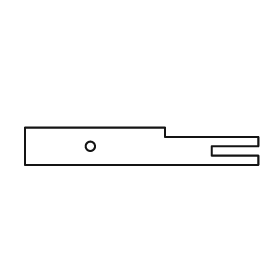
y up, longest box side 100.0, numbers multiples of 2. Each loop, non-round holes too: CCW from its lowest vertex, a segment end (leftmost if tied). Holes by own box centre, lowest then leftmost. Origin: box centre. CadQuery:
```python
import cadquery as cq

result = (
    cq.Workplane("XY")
    .moveTo(-50.0, -8.0)
    .lineTo(50.0, -8.0)
    .lineTo(50.0, -4.0)
    .lineTo(30.0, -4.0)
    .lineTo(30.0, 0.0)
    .lineTo(50.0, 0.0)
    .lineTo(50.0, 4.0)
    .lineTo(10.0, 4.0)
    .lineTo(10.0, 8.0)
    .lineTo(-50.0, 8.0)
    .close()
    .moveTo(-22.0, 0.0)
    .circle(2.0)
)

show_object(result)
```